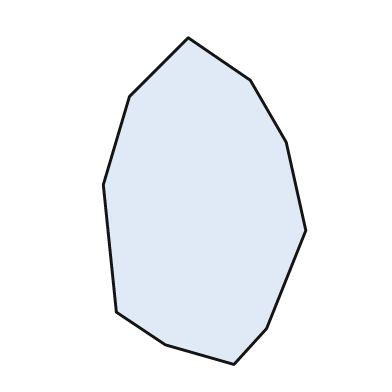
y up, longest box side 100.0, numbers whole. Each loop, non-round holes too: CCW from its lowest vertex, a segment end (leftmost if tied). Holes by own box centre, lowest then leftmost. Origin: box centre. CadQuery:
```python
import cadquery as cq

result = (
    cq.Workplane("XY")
    .moveTo(9.0, -50.0)
    .lineTo(19.0, -39.0)
    .lineTo(31.0, -9.0)
    .lineTo(25.0, 18.0)
    .lineTo(14.0, 37.0)
    .lineTo(-5.0, 50.0)
    .lineTo(-23.0, 32.0)
    .lineTo(-31.0, 5.0)
    .lineTo(-27.0, -34.0)
    .lineTo(-12.0, -44.0)
    .close()
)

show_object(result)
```